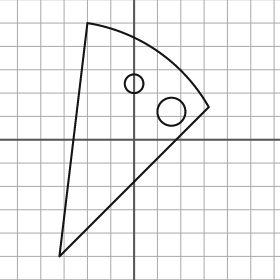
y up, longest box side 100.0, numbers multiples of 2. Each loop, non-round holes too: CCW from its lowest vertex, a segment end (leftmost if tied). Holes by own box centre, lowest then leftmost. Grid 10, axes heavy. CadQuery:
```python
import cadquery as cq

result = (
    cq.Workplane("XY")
    .moveTo(-32.0, -50.0)
    .lineTo(32.0, 14.0)
    .threePointArc((10.0, 38.0), (-20.0, 50.0))
    .close()
    .moveTo(16.0, 12.0)
    .circle(6.0)
    .moveTo(0.0, 24.0)
    .circle(4.0)
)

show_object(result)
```